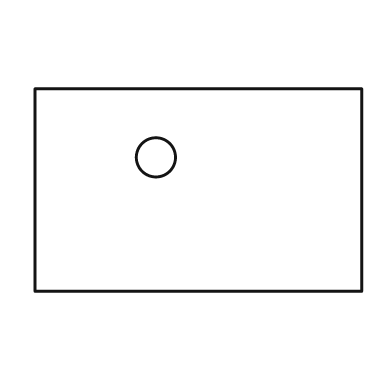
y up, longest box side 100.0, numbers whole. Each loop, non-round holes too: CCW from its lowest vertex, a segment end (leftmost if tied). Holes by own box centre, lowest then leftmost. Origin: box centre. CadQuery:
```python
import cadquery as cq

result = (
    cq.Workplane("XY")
    .moveTo(-50.0, -31.0)
    .lineTo(50.0, -31.0)
    .lineTo(50.0, 31.0)
    .lineTo(-50.0, 31.0)
    .close()
    .moveTo(-13.0, 10.0)
    .circle(6.0)
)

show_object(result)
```